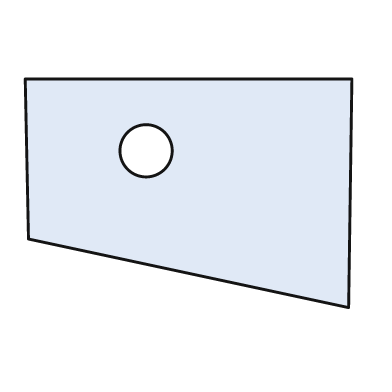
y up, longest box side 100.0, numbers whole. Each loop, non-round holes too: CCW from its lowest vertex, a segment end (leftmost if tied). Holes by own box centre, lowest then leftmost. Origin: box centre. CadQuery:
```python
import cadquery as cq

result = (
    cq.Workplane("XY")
    .moveTo(49.0, -35.0)
    .lineTo(50.0, 35.0)
    .lineTo(-50.0, 35.0)
    .lineTo(-49.0, -14.0)
    .close()
    .moveTo(-13.0, 13.0)
    .circle(8.0)
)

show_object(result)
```